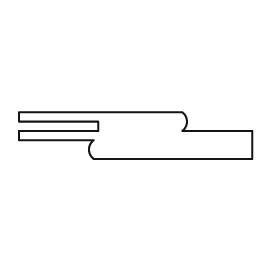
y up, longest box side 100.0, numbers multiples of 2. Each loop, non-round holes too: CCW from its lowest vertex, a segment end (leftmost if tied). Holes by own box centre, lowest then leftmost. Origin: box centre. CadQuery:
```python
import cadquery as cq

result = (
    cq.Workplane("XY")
    .moveTo(-18.0, -10.0)
    .lineTo(50.0, -10.0)
    .lineTo(50.0, 2.0)
    .lineTo(20.0, 2.0)
    .threePointArc((22.0, 6.0), (20.0, 10.0))
    .lineTo(-50.0, 10.0)
    .lineTo(-50.0, 6.0)
    .lineTo(-16.0, 6.0)
    .lineTo(-16.0, 2.0)
    .lineTo(-50.0, 2.0)
    .lineTo(-50.0, -2.0)
    .lineTo(-18.0, -2.0)
    .threePointArc((-20.0, -6.0), (-18.0, -10.0))
    .close()
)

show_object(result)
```